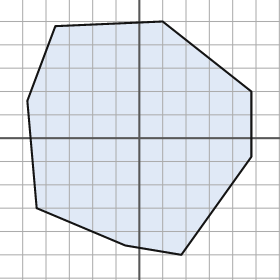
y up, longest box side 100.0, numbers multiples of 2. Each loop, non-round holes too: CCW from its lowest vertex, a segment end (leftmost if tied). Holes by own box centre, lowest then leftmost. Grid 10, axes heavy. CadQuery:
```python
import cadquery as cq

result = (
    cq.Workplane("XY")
    .moveTo(18.0, -50.0)
    .lineTo(48.0, -8.0)
    .lineTo(48.0, 20.0)
    .lineTo(10.0, 50.0)
    .lineTo(-36.0, 48.0)
    .lineTo(-48.0, 16.0)
    .lineTo(-44.0, -30.0)
    .lineTo(-6.0, -46.0)
    .close()
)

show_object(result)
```